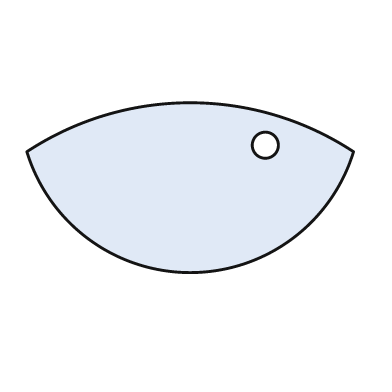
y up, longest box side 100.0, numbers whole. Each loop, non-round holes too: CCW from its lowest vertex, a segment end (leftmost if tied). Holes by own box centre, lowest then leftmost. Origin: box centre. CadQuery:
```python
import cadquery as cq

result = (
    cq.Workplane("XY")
    .moveTo(-50.0, 11.0)
    .threePointArc((0.0, -26.0), (50.0, 11.0))
    .threePointArc((0.0, 26.0), (-50.0, 11.0))
    .close()
    .moveTo(23.0, 13.0)
    .circle(4.0)
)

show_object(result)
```